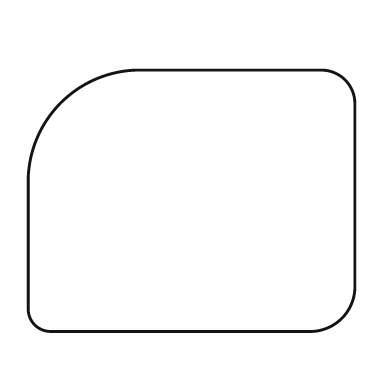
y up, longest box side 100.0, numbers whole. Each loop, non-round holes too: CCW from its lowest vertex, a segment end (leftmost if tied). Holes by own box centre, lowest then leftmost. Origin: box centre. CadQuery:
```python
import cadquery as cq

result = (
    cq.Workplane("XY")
    .moveTo(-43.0, -40.0)
    .lineTo(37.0, -40.0)
    .threePointArc((46.0, -36.0), (50.0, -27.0))
    .lineTo(50.0, 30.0)
    .threePointArc((47.0, 37.0), (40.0, 40.0))
    .lineTo(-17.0, 40.0)
    .threePointArc((-40.0, 30.0), (-50.0, 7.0))
    .lineTo(-50.0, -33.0)
    .threePointArc((-48.0, -38.0), (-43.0, -40.0))
    .close()
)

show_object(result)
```